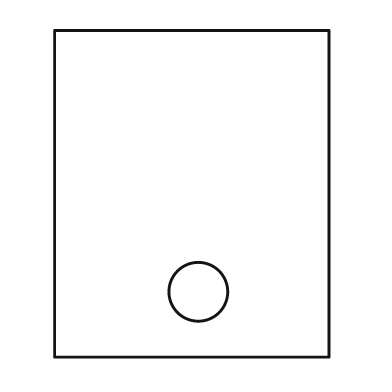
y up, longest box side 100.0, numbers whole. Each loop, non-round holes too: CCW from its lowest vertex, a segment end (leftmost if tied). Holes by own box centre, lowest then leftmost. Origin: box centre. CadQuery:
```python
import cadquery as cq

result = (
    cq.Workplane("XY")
    .moveTo(-42.0, -50.0)
    .lineTo(42.0, -50.0)
    .lineTo(42.0, 50.0)
    .lineTo(-42.0, 50.0)
    .close()
    .moveTo(2.0, -30.0)
    .circle(9.0)
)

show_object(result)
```